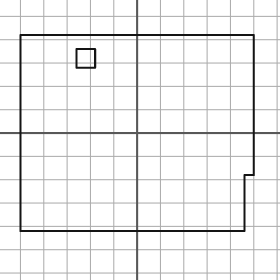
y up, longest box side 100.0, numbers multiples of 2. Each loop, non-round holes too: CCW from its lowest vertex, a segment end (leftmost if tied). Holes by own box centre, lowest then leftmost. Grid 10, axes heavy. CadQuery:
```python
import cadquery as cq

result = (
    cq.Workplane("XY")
    .moveTo(-50.0, -42.0)
    .lineTo(46.0, -42.0)
    .lineTo(46.0, -18.0)
    .lineTo(50.0, -18.0)
    .lineTo(50.0, 42.0)
    .lineTo(-50.0, 42.0)
    .close()
    .moveTo(-26.0, 28.0)
    .lineTo(-18.0, 28.0)
    .lineTo(-18.0, 36.0)
    .lineTo(-26.0, 36.0)
    .close()
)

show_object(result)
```